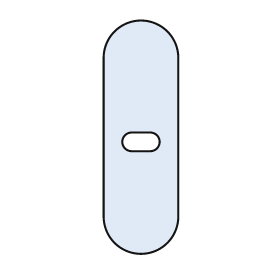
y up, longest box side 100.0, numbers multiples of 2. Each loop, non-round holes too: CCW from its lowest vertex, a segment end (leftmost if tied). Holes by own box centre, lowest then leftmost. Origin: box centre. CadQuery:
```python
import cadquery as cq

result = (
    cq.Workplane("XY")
    .moveTo(-16.0, -34.0)
    .threePointArc((0.0, -50.0), (16.0, -34.0))
    .lineTo(16.0, 34.0)
    .threePointArc((0.0, 50.0), (-16.0, 34.0))
    .close()
    .moveTo(-4.0, -6.0)
    .lineTo(4.0, -6.0)
    .threePointArc((8.0, -2.0), (4.0, 2.0))
    .lineTo(-4.0, 2.0)
    .threePointArc((-8.0, -2.0), (-4.0, -6.0))
    .close()
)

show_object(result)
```